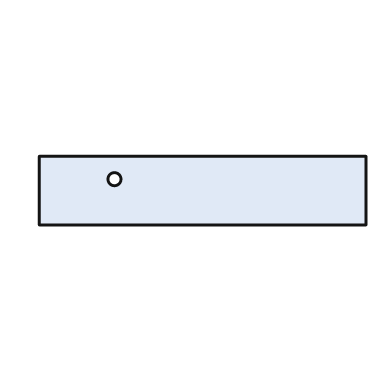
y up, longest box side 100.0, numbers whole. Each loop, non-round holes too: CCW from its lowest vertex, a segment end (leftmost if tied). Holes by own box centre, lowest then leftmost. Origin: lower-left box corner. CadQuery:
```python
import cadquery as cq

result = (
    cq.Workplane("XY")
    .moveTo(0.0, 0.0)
    .lineTo(100.0, 0.0)
    .lineTo(100.0, 21.0)
    .lineTo(0.0, 21.0)
    .close()
    .moveTo(23.0, 14.0)
    .circle(2.0)
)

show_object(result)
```